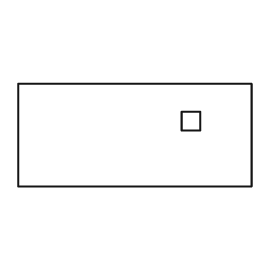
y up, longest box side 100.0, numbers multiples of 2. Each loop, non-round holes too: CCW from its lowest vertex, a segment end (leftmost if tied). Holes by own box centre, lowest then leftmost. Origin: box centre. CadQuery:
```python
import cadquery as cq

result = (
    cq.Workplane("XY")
    .moveTo(-50.0, -22.0)
    .lineTo(50.0, -22.0)
    .lineTo(50.0, 22.0)
    .lineTo(-50.0, 22.0)
    .close()
    .moveTo(20.0, 2.0)
    .lineTo(28.0, 2.0)
    .lineTo(28.0, 10.0)
    .lineTo(20.0, 10.0)
    .close()
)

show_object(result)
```